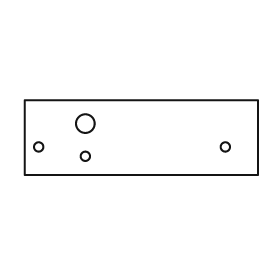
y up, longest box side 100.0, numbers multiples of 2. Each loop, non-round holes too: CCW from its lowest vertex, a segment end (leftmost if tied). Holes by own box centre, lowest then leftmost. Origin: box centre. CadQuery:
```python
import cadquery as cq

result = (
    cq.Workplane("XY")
    .moveTo(-50.0, -16.0)
    .lineTo(50.0, -16.0)
    .lineTo(50.0, 16.0)
    .lineTo(-50.0, 16.0)
    .close()
    .moveTo(-24.0, -8.0)
    .circle(2.0)
    .moveTo(-44.0, -4.0)
    .circle(2.0)
    .moveTo(36.0, -4.0)
    .circle(2.0)
    .moveTo(-24.0, 6.0)
    .circle(4.0)
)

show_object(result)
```